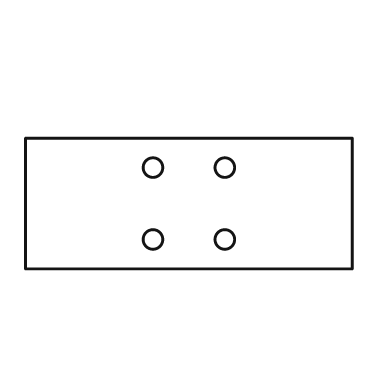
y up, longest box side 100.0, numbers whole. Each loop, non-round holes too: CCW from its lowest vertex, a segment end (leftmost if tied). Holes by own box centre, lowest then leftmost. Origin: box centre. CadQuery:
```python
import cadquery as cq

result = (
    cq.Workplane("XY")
    .moveTo(-50.0, -20.0)
    .lineTo(50.0, -20.0)
    .lineTo(50.0, 20.0)
    .lineTo(-50.0, 20.0)
    .close()
    .moveTo(-11.0, -11.0)
    .circle(3.0)
    .moveTo(11.0, -11.0)
    .circle(3.0)
    .moveTo(-11.0, 11.0)
    .circle(3.0)
    .moveTo(11.0, 11.0)
    .circle(3.0)
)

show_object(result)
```